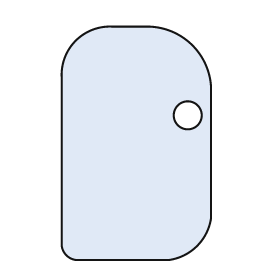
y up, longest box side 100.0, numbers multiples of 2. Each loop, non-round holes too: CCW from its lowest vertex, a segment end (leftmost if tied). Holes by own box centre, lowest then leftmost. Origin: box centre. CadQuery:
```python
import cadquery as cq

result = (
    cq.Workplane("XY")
    .moveTo(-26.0, -50.0)
    .lineTo(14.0, -50.0)
    .threePointArc((26.0, -44.0), (32.0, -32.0))
    .lineTo(32.0, 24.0)
    .threePointArc((24.0, 42.0), (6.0, 50.0))
    .lineTo(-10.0, 50.0)
    .threePointArc((-26.0, 44.0), (-32.0, 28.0))
    .lineTo(-32.0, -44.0)
    .threePointArc((-30.0, -48.0), (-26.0, -50.0))
    .close()
    .moveTo(22.0, 12.0)
    .circle(6.0)
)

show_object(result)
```